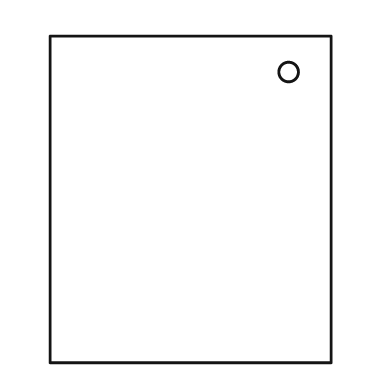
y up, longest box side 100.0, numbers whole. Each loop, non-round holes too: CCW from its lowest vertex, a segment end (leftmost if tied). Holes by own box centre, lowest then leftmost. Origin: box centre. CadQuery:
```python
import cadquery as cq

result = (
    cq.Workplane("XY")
    .moveTo(-43.0, -50.0)
    .lineTo(43.0, -50.0)
    .lineTo(43.0, 50.0)
    .lineTo(-43.0, 50.0)
    .close()
    .moveTo(30.0, 39.0)
    .circle(3.0)
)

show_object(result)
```